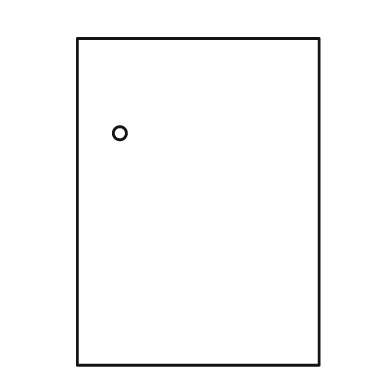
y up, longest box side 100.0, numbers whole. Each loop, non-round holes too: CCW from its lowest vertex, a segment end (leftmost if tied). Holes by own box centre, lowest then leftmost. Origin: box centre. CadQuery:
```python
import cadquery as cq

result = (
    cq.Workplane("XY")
    .moveTo(-37.0, -50.0)
    .lineTo(37.0, -50.0)
    .lineTo(37.0, 50.0)
    .lineTo(-37.0, 50.0)
    .close()
    .moveTo(-24.0, 21.0)
    .circle(2.0)
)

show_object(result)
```